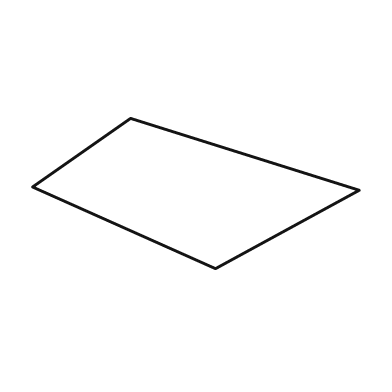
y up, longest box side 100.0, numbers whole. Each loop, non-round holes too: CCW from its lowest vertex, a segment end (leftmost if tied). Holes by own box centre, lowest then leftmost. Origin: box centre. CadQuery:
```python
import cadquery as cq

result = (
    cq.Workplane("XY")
    .moveTo(6.0, -23.0)
    .lineTo(50.0, 1.0)
    .lineTo(-20.0, 23.0)
    .lineTo(-50.0, 2.0)
    .close()
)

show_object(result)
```